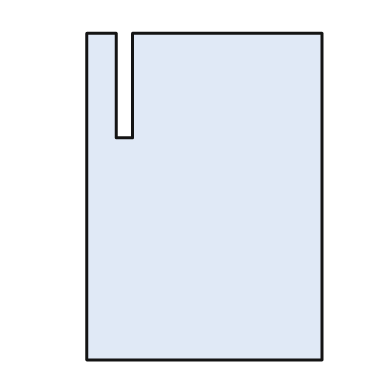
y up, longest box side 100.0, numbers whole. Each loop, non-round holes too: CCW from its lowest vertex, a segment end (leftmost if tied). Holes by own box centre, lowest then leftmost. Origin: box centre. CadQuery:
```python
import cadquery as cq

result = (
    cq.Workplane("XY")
    .moveTo(-36.0, -50.0)
    .lineTo(36.0, -50.0)
    .lineTo(36.0, 50.0)
    .lineTo(-22.0, 50.0)
    .lineTo(-22.0, 18.0)
    .lineTo(-27.0, 18.0)
    .lineTo(-27.0, 50.0)
    .lineTo(-36.0, 50.0)
    .close()
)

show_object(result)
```